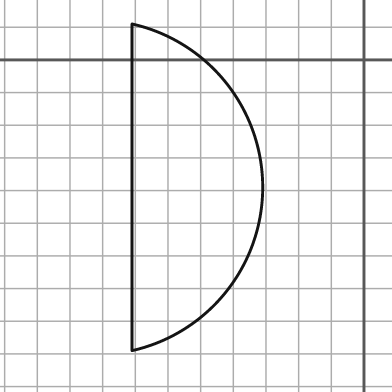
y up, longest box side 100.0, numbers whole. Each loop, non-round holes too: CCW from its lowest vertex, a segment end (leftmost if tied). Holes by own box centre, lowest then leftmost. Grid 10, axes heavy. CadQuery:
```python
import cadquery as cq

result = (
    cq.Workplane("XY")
    .moveTo(-71.0, -89.0)
    .threePointArc((-31.0, -39.0), (-71.0, 11.0))
    .close()
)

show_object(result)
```